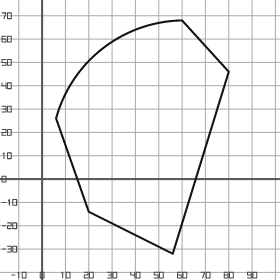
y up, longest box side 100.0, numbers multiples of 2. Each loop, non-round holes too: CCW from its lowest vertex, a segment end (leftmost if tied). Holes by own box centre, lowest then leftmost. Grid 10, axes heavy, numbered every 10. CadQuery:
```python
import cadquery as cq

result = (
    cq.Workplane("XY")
    .moveTo(56.0, -32.0)
    .lineTo(80.0, 46.0)
    .lineTo(60.0, 68.0)
    .threePointArc((26.0, 56.0), (6.0, 26.0))
    .lineTo(20.0, -14.0)
    .close()
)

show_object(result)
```